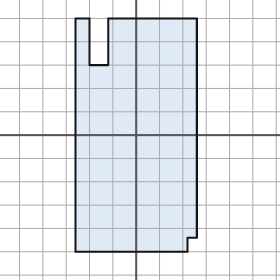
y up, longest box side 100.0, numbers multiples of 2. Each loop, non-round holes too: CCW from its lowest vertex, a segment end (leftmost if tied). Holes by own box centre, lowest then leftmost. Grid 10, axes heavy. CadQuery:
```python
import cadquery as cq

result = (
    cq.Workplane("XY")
    .moveTo(-26.0, -50.0)
    .lineTo(22.0, -50.0)
    .lineTo(22.0, -44.0)
    .lineTo(26.0, -44.0)
    .lineTo(26.0, 50.0)
    .lineTo(-12.0, 50.0)
    .lineTo(-12.0, 30.0)
    .lineTo(-20.0, 30.0)
    .lineTo(-20.0, 50.0)
    .lineTo(-26.0, 50.0)
    .close()
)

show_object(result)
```